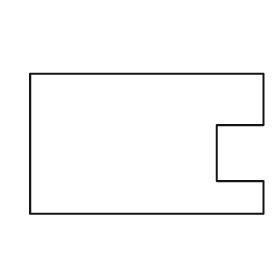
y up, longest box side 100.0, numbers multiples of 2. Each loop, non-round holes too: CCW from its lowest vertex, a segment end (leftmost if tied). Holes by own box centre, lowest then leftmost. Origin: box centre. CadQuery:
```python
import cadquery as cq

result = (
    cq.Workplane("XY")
    .moveTo(-50.0, -30.0)
    .lineTo(50.0, -30.0)
    .lineTo(50.0, -16.0)
    .lineTo(30.0, -16.0)
    .lineTo(30.0, 8.0)
    .lineTo(50.0, 8.0)
    .lineTo(50.0, 30.0)
    .lineTo(-50.0, 30.0)
    .close()
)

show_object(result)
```